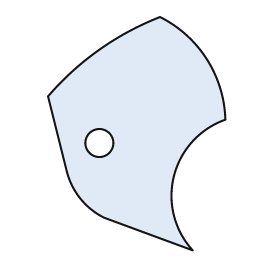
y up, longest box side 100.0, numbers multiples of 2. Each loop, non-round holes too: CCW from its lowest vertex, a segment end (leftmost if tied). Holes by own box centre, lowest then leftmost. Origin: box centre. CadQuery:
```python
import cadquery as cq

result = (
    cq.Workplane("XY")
    .moveTo(24.0, -50.0)
    .threePointArc((16.0, -18.0), (38.0, 6.0))
    .threePointArc((30.0, 32.0), (10.0, 50.0))
    .threePointArc((-16.0, 36.0), (-38.0, 16.0))
    .lineTo(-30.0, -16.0)
    .threePointArc((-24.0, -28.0), (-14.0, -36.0))
    .close()
    .moveTo(-16.0, -4.0)
    .circle(6.0)
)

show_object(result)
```